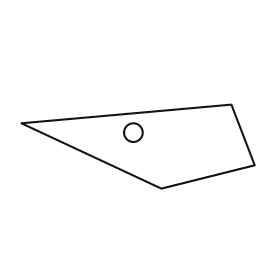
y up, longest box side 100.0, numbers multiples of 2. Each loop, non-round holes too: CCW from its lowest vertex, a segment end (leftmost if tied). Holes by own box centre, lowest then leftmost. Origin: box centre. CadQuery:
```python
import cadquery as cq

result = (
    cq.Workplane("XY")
    .moveTo(10.0, -18.0)
    .lineTo(50.0, -8.0)
    .lineTo(40.0, 18.0)
    .lineTo(-50.0, 10.0)
    .close()
    .moveTo(-2.0, 6.0)
    .circle(4.0)
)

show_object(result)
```